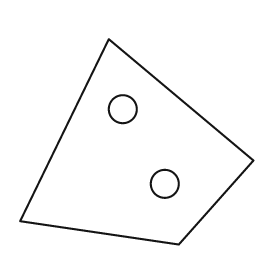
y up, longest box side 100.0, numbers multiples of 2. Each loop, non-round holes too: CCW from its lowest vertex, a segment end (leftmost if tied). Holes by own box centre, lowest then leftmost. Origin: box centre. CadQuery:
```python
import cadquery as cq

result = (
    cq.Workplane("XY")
    .moveTo(18.0, -44.0)
    .lineTo(50.0, -8.0)
    .lineTo(-12.0, 44.0)
    .lineTo(-50.0, -34.0)
    .close()
    .moveTo(12.0, -18.0)
    .circle(6.0)
    .moveTo(-6.0, 14.0)
    .circle(6.0)
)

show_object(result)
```